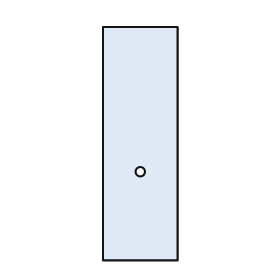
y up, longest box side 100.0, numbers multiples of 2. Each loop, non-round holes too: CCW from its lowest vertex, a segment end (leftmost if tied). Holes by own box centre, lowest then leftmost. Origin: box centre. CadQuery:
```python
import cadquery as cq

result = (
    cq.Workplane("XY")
    .moveTo(-16.0, -50.0)
    .lineTo(16.0, -50.0)
    .lineTo(16.0, 50.0)
    .lineTo(-16.0, 50.0)
    .close()
    .moveTo(0.0, -12.0)
    .circle(2.0)
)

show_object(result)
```